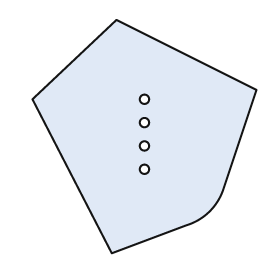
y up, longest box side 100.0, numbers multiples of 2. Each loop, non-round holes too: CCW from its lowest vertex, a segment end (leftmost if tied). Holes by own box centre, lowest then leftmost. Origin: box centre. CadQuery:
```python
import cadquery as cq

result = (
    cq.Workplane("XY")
    .moveTo(-14.0, -50.0)
    .lineTo(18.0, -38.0)
    .threePointArc((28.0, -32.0), (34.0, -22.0))
    .lineTo(48.0, 20.0)
    .lineTo(-12.0, 50.0)
    .lineTo(-48.0, 16.0)
    .close()
    .moveTo(0.0, -14.0)
    .circle(2.0)
    .moveTo(0.0, -4.0)
    .circle(2.0)
    .moveTo(0.0, 6.0)
    .circle(2.0)
    .moveTo(0.0, 16.0)
    .circle(2.0)
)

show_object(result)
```